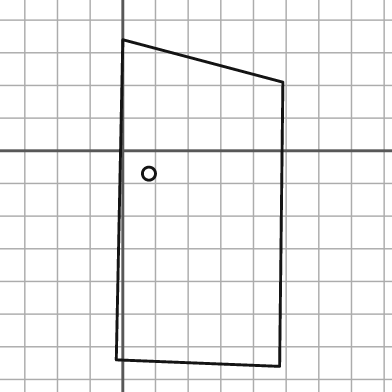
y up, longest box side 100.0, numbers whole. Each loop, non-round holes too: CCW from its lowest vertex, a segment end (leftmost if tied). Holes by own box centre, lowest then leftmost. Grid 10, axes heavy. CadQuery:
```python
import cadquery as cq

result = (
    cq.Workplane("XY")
    .moveTo(48.0, -66.0)
    .lineTo(49.0, 21.0)
    .lineTo(0.0, 34.0)
    .lineTo(-2.0, -64.0)
    .close()
    .moveTo(8.0, -7.0)
    .circle(2.0)
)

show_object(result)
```